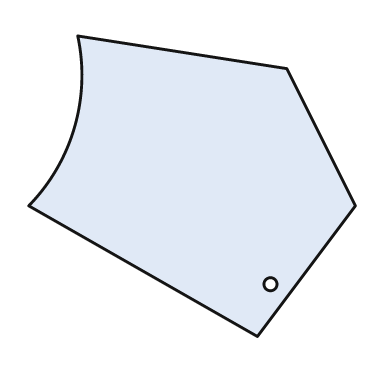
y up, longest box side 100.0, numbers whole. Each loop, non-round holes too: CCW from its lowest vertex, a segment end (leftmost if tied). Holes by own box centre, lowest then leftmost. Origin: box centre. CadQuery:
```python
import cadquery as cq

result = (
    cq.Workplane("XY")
    .moveTo(20.0, -46.0)
    .lineTo(50.0, -6.0)
    .lineTo(29.0, 36.0)
    .lineTo(-35.0, 46.0)
    .threePointArc((-36.0, 18.0), (-50.0, -6.0))
    .close()
    .moveTo(24.0, -30.0)
    .circle(2.0)
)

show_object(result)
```